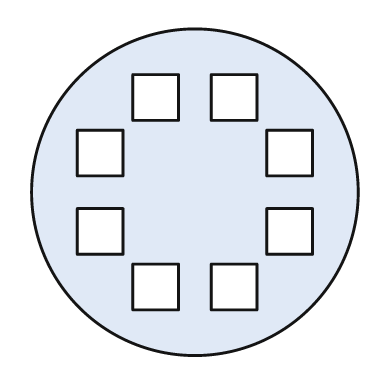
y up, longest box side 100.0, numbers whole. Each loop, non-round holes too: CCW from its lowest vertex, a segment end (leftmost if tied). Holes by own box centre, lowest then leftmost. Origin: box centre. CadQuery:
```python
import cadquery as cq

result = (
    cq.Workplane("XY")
    .moveTo(0.0, 0.0)
    .circle(50.0)
    .moveTo(-19.0, -36.0)
    .lineTo(-5.0, -36.0)
    .lineTo(-5.0, -22.0)
    .lineTo(-19.0, -22.0)
    .close()
    .moveTo(5.0, -36.0)
    .lineTo(19.0, -36.0)
    .lineTo(19.0, -22.0)
    .lineTo(5.0, -22.0)
    .close()
    .moveTo(-36.0, -19.0)
    .lineTo(-22.0, -19.0)
    .lineTo(-22.0, -5.0)
    .lineTo(-36.0, -5.0)
    .close()
    .moveTo(22.0, -19.0)
    .lineTo(36.0, -19.0)
    .lineTo(36.0, -5.0)
    .lineTo(22.0, -5.0)
    .close()
    .moveTo(-36.0, 5.0)
    .lineTo(-22.0, 5.0)
    .lineTo(-22.0, 19.0)
    .lineTo(-36.0, 19.0)
    .close()
    .moveTo(22.0, 5.0)
    .lineTo(36.0, 5.0)
    .lineTo(36.0, 19.0)
    .lineTo(22.0, 19.0)
    .close()
    .moveTo(-19.0, 22.0)
    .lineTo(-5.0, 22.0)
    .lineTo(-5.0, 36.0)
    .lineTo(-19.0, 36.0)
    .close()
    .moveTo(5.0, 22.0)
    .lineTo(19.0, 22.0)
    .lineTo(19.0, 36.0)
    .lineTo(5.0, 36.0)
    .close()
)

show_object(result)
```